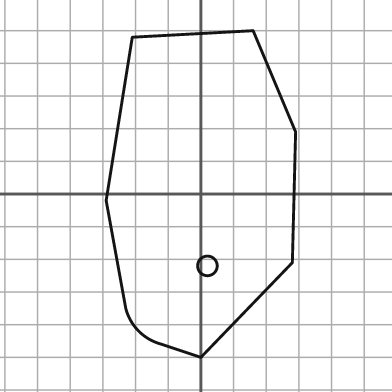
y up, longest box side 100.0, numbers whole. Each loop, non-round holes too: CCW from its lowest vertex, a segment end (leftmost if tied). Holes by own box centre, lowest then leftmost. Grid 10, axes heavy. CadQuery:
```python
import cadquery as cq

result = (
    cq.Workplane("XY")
    .moveTo(0.0, -50.0)
    .lineTo(28.0, -21.0)
    .lineTo(29.0, 19.0)
    .lineTo(16.0, 50.0)
    .lineTo(-21.0, 48.0)
    .lineTo(-29.0, -2.0)
    .lineTo(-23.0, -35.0)
    .threePointArc((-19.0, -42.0), (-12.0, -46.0))
    .close()
    .moveTo(2.0, -22.0)
    .circle(3.0)
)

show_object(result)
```